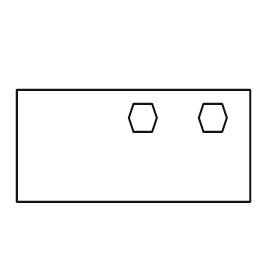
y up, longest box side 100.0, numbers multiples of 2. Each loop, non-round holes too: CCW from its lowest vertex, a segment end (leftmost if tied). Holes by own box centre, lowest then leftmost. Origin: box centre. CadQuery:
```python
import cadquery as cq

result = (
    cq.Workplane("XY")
    .moveTo(-50.0, -24.0)
    .lineTo(50.0, -24.0)
    .lineTo(50.0, 24.0)
    .lineTo(-50.0, 24.0)
    .close()
    .moveTo(0.0, 6.0)
    .lineTo(8.0, 6.0)
    .lineTo(10.0, 12.0)
    .lineTo(8.0, 18.0)
    .lineTo(0.0, 18.0)
    .lineTo(-2.0, 12.0)
    .close()
    .moveTo(30.0, 6.0)
    .lineTo(38.0, 6.0)
    .lineTo(40.0, 12.0)
    .lineTo(38.0, 18.0)
    .lineTo(30.0, 18.0)
    .lineTo(28.0, 12.0)
    .close()
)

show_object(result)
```